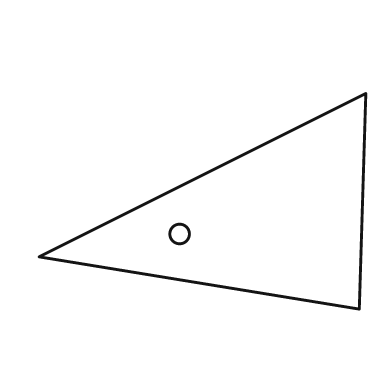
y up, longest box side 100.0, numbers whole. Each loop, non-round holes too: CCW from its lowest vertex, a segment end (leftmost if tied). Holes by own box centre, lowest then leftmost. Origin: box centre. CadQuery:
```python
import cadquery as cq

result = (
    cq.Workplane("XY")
    .moveTo(48.0, -33.0)
    .lineTo(50.0, 33.0)
    .lineTo(-50.0, -17.0)
    .close()
    .moveTo(-7.0, -10.0)
    .circle(3.0)
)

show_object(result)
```